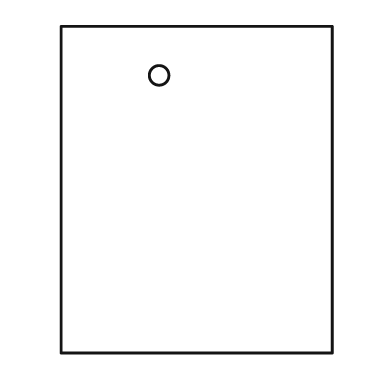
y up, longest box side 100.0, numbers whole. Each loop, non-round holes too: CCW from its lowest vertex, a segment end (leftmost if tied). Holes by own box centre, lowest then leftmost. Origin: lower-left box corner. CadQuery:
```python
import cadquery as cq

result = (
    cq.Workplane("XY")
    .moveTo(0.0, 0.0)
    .lineTo(83.0, 0.0)
    .lineTo(83.0, 100.0)
    .lineTo(0.0, 100.0)
    .close()
    .moveTo(30.0, 85.0)
    .circle(3.0)
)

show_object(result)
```